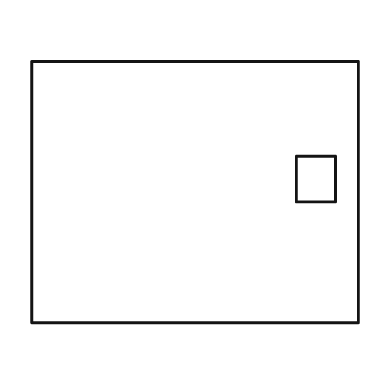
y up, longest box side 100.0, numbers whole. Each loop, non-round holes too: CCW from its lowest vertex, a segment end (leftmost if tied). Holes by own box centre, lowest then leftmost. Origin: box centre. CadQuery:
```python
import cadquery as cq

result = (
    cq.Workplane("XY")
    .moveTo(-50.0, -40.0)
    .lineTo(50.0, -40.0)
    .lineTo(50.0, 40.0)
    .lineTo(-50.0, 40.0)
    .close()
    .moveTo(31.0, -3.0)
    .lineTo(43.0, -3.0)
    .lineTo(43.0, 11.0)
    .lineTo(31.0, 11.0)
    .close()
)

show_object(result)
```